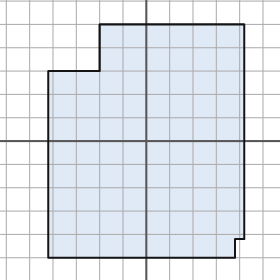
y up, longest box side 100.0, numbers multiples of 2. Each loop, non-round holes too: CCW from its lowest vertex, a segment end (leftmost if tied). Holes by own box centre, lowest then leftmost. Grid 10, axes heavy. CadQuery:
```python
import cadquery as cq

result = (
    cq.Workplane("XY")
    .moveTo(-42.0, -50.0)
    .lineTo(38.0, -50.0)
    .lineTo(38.0, -42.0)
    .lineTo(42.0, -42.0)
    .lineTo(42.0, 50.0)
    .lineTo(-20.0, 50.0)
    .lineTo(-20.0, 30.0)
    .lineTo(-42.0, 30.0)
    .close()
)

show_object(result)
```